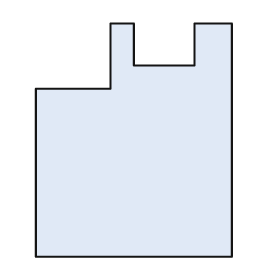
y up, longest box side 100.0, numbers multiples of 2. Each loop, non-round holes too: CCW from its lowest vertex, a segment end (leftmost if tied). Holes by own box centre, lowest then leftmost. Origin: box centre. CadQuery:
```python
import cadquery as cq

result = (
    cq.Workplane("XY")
    .moveTo(-42.0, -50.0)
    .lineTo(42.0, -50.0)
    .lineTo(42.0, 50.0)
    .lineTo(26.0, 50.0)
    .lineTo(26.0, 32.0)
    .lineTo(0.0, 32.0)
    .lineTo(0.0, 50.0)
    .lineTo(-10.0, 50.0)
    .lineTo(-10.0, 22.0)
    .lineTo(-42.0, 22.0)
    .close()
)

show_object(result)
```